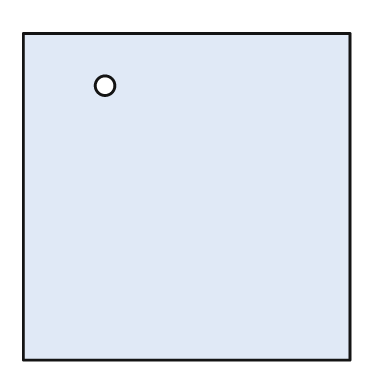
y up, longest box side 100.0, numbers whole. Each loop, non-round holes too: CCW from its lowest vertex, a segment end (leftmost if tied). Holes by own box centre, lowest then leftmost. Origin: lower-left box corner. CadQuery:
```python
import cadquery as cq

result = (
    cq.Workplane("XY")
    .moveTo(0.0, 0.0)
    .lineTo(100.0, 0.0)
    .lineTo(100.0, 100.0)
    .lineTo(0.0, 100.0)
    .close()
    .moveTo(25.0, 84.0)
    .circle(3.0)
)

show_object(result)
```